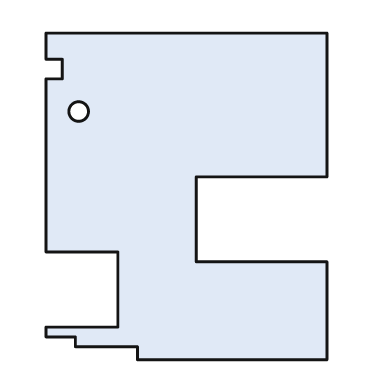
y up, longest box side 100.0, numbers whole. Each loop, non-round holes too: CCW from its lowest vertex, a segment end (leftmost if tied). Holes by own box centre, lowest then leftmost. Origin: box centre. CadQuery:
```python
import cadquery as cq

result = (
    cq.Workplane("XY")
    .moveTo(-15.0, -50.0)
    .lineTo(43.0, -50.0)
    .lineTo(43.0, -20.0)
    .lineTo(3.0, -20.0)
    .lineTo(3.0, 6.0)
    .lineTo(43.0, 6.0)
    .lineTo(43.0, 50.0)
    .lineTo(-43.0, 50.0)
    .lineTo(-43.0, 42.0)
    .lineTo(-38.0, 42.0)
    .lineTo(-38.0, 36.0)
    .lineTo(-43.0, 36.0)
    .lineTo(-43.0, -17.0)
    .lineTo(-21.0, -17.0)
    .lineTo(-21.0, -40.0)
    .lineTo(-43.0, -40.0)
    .lineTo(-43.0, -43.0)
    .lineTo(-34.0, -43.0)
    .lineTo(-34.0, -46.0)
    .lineTo(-15.0, -46.0)
    .close()
    .moveTo(-33.0, 26.0)
    .circle(3.0)
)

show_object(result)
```